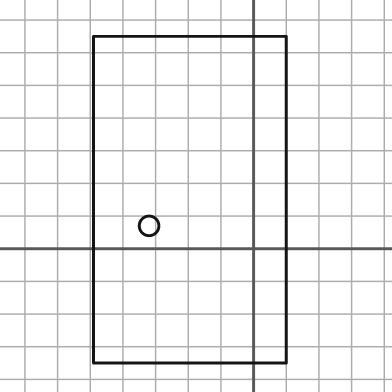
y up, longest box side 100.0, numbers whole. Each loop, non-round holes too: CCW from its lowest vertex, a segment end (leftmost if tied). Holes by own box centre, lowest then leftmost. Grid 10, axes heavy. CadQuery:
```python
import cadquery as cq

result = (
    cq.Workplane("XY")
    .moveTo(-49.0, -35.0)
    .lineTo(10.0, -35.0)
    .lineTo(10.0, 65.0)
    .lineTo(-49.0, 65.0)
    .close()
    .moveTo(-32.0, 7.0)
    .circle(3.0)
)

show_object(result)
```